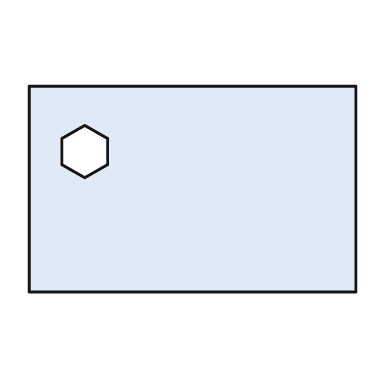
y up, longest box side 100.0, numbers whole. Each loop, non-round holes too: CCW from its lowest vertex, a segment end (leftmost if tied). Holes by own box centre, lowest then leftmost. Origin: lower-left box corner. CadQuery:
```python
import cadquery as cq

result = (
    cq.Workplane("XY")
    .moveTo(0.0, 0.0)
    .lineTo(100.0, 0.0)
    .lineTo(100.0, 63.0)
    .lineTo(0.0, 63.0)
    .close()
    .moveTo(17.0, 35.0)
    .lineTo(24.0, 39.0)
    .lineTo(24.0, 47.0)
    .lineTo(17.0, 51.0)
    .lineTo(10.0, 47.0)
    .lineTo(10.0, 39.0)
    .close()
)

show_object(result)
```